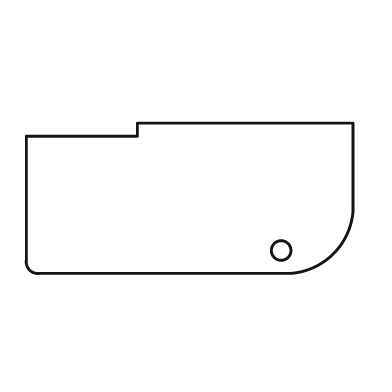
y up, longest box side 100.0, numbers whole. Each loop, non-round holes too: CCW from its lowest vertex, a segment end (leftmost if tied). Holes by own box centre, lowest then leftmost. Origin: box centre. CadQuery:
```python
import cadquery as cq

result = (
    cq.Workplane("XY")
    .moveTo(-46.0, -23.0)
    .lineTo(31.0, -23.0)
    .threePointArc((44.0, -17.0), (50.0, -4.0))
    .lineTo(50.0, 23.0)
    .lineTo(-16.0, 23.0)
    .lineTo(-16.0, 19.0)
    .lineTo(-50.0, 19.0)
    .lineTo(-50.0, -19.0)
    .threePointArc((-49.0, -22.0), (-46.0, -23.0))
    .close()
    .moveTo(28.0, -16.0)
    .circle(3.0)
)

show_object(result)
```